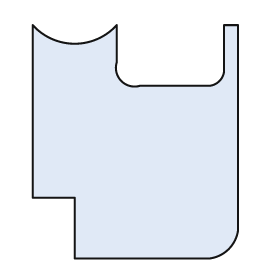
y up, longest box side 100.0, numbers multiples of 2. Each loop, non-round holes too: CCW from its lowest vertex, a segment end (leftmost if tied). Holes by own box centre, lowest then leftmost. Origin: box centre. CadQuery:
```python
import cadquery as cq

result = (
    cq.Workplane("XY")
    .moveTo(-26.0, -50.0)
    .lineTo(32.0, -50.0)
    .threePointArc((40.0, -46.0), (44.0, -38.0))
    .lineTo(44.0, 50.0)
    .lineTo(38.0, 50.0)
    .lineTo(38.0, 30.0)
    .threePointArc((36.0, 26.0), (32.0, 24.0))
    .lineTo(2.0, 24.0)
    .threePointArc((-6.0, 26.0), (-8.0, 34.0))
    .lineTo(-8.0, 50.0)
    .threePointArc((-26.0, 42.0), (-44.0, 50.0))
    .lineTo(-44.0, -24.0)
    .lineTo(-26.0, -24.0)
    .close()
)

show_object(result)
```